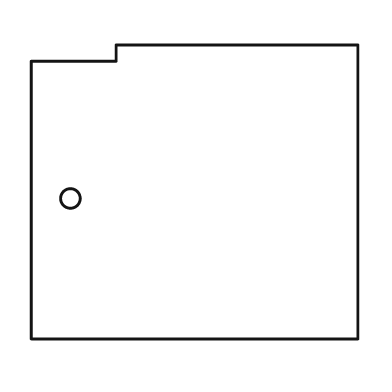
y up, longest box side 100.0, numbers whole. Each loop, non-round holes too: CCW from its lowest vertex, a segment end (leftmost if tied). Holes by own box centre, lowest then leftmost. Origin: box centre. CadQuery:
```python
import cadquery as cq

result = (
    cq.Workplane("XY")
    .moveTo(-50.0, -45.0)
    .lineTo(50.0, -45.0)
    .lineTo(50.0, 45.0)
    .lineTo(-24.0, 45.0)
    .lineTo(-24.0, 40.0)
    .lineTo(-50.0, 40.0)
    .close()
    .moveTo(-38.0, -2.0)
    .circle(3.0)
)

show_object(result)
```